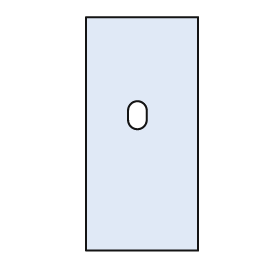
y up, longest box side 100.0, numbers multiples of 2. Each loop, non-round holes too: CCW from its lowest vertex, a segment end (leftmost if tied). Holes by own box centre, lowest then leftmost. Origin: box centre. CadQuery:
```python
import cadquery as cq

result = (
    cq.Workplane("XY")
    .moveTo(-24.0, -50.0)
    .lineTo(24.0, -50.0)
    .lineTo(24.0, 50.0)
    .lineTo(-24.0, 50.0)
    .close()
    .moveTo(-6.0, 6.0)
    .threePointArc((-2.0, 2.0), (2.0, 6.0))
    .lineTo(2.0, 10.0)
    .threePointArc((-2.0, 14.0), (-6.0, 10.0))
    .close()
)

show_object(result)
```